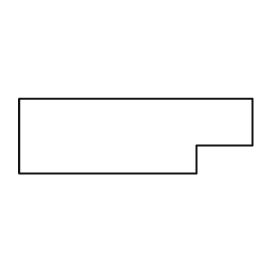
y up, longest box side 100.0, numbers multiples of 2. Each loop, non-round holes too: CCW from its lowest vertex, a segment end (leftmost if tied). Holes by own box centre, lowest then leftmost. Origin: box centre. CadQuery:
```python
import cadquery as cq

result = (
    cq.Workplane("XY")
    .moveTo(-50.0, -16.0)
    .lineTo(26.0, -16.0)
    .lineTo(26.0, -4.0)
    .lineTo(50.0, -4.0)
    .lineTo(50.0, 16.0)
    .lineTo(-50.0, 16.0)
    .close()
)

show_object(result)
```